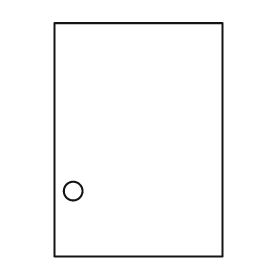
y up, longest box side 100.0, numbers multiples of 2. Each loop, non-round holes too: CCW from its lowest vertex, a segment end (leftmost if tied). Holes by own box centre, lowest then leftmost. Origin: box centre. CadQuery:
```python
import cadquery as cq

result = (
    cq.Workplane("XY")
    .moveTo(-36.0, -50.0)
    .lineTo(36.0, -50.0)
    .lineTo(36.0, 50.0)
    .lineTo(-36.0, 50.0)
    .close()
    .moveTo(-28.0, -22.0)
    .circle(4.0)
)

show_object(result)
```